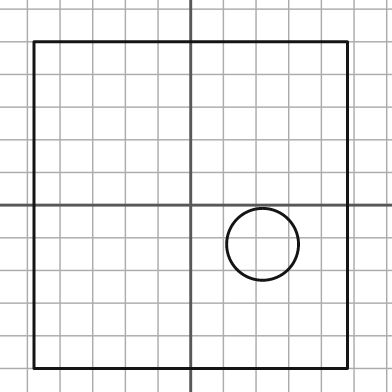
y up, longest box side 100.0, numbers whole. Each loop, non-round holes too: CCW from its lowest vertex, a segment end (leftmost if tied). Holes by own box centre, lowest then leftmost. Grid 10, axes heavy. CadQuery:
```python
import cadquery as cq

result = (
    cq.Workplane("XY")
    .moveTo(-48.0, -50.0)
    .lineTo(48.0, -50.0)
    .lineTo(48.0, 50.0)
    .lineTo(-48.0, 50.0)
    .close()
    .moveTo(22.0, -12.0)
    .circle(11.0)
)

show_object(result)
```